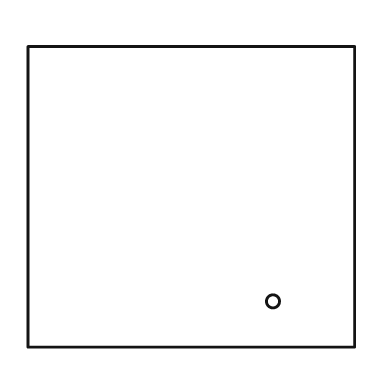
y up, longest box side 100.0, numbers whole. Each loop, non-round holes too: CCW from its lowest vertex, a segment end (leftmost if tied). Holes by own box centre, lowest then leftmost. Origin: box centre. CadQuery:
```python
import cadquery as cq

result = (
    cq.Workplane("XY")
    .moveTo(-50.0, -46.0)
    .lineTo(50.0, -46.0)
    .lineTo(50.0, 46.0)
    .lineTo(-50.0, 46.0)
    .close()
    .moveTo(25.0, -32.0)
    .circle(2.0)
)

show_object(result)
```